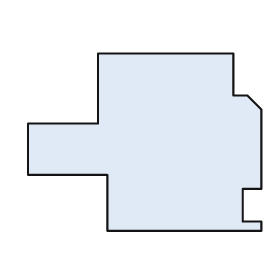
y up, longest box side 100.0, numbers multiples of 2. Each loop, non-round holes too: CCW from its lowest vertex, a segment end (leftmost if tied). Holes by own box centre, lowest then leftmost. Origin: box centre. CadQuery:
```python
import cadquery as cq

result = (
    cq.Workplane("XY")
    .moveTo(-16.0, -38.0)
    .lineTo(50.0, -38.0)
    .lineTo(50.0, -34.0)
    .lineTo(42.0, -34.0)
    .lineTo(42.0, -20.0)
    .lineTo(50.0, -20.0)
    .lineTo(50.0, 14.0)
    .lineTo(44.0, 20.0)
    .lineTo(38.0, 20.0)
    .lineTo(38.0, 38.0)
    .lineTo(-20.0, 38.0)
    .lineTo(-20.0, 8.0)
    .lineTo(-50.0, 8.0)
    .lineTo(-50.0, -14.0)
    .lineTo(-16.0, -14.0)
    .close()
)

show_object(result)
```